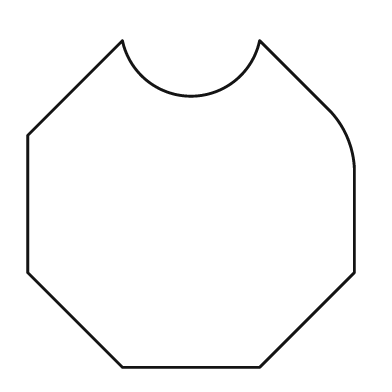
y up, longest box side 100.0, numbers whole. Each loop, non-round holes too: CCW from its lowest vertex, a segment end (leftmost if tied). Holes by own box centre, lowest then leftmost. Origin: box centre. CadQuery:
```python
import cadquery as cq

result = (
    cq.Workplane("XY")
    .moveTo(-21.0, -50.0)
    .lineTo(21.0, -50.0)
    .lineTo(50.0, -21.0)
    .lineTo(50.0, 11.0)
    .threePointArc((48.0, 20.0), (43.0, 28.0))
    .lineTo(21.0, 50.0)
    .threePointArc((0.0, 33.0), (-21.0, 50.0))
    .lineTo(-50.0, 21.0)
    .lineTo(-50.0, -21.0)
    .close()
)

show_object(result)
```